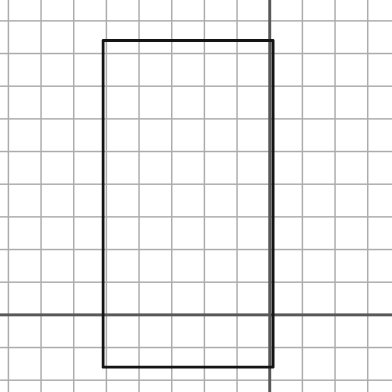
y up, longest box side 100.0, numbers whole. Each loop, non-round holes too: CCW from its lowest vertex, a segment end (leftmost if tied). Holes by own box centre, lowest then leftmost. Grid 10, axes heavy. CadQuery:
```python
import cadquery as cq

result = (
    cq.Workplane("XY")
    .moveTo(-51.0, -16.0)
    .lineTo(1.0, -16.0)
    .lineTo(1.0, 84.0)
    .lineTo(-51.0, 84.0)
    .close()
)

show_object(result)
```